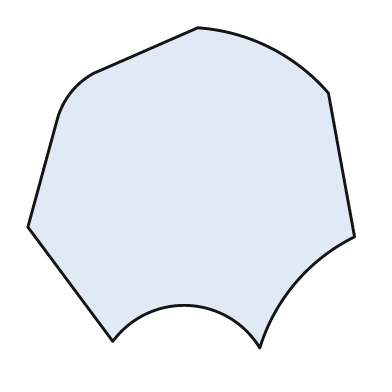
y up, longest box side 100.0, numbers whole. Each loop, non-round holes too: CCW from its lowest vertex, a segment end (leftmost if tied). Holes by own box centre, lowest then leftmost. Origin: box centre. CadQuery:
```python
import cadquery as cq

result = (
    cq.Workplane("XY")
    .moveTo(21.0, -49.0)
    .threePointArc((32.0, -29.0), (50.0, -15.0))
    .lineTo(42.0, 29.0)
    .threePointArc((24.0, 43.0), (2.0, 49.0))
    .lineTo(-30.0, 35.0)
    .threePointArc((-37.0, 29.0), (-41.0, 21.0))
    .lineTo(-50.0, -12.0)
    .lineTo(-24.0, -47.0)
    .threePointArc((-1.0, -36.0), (21.0, -49.0))
    .close()
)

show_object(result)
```